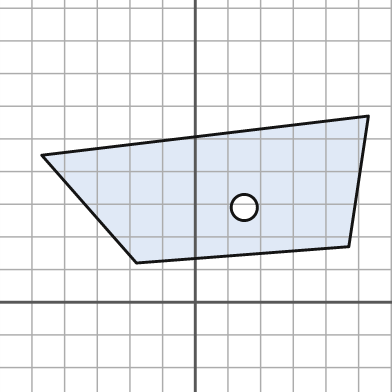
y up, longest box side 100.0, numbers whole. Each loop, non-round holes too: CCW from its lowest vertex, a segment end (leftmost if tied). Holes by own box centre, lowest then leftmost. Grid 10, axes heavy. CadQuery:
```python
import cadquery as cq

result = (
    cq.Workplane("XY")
    .moveTo(-18.0, 12.0)
    .lineTo(47.0, 17.0)
    .lineTo(53.0, 57.0)
    .lineTo(-47.0, 45.0)
    .close()
    .moveTo(15.0, 29.0)
    .circle(4.0)
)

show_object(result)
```